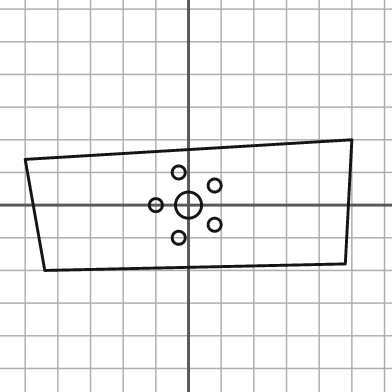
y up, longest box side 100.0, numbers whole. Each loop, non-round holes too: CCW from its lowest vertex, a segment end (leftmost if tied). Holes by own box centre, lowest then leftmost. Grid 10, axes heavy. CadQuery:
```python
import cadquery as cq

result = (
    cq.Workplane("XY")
    .moveTo(-44.0, -20.0)
    .lineTo(48.0, -18.0)
    .lineTo(50.0, 20.0)
    .lineTo(-50.0, 14.0)
    .close()
    .moveTo(-3.0, -10.0)
    .circle(2.0)
    .moveTo(8.0, -6.0)
    .circle(2.0)
    .moveTo(-10.0, 0.0)
    .circle(2.0)
    .moveTo(0.0, 0.0)
    .circle(4.0)
    .moveTo(8.0, 6.0)
    .circle(2.0)
    .moveTo(-3.0, 10.0)
    .circle(2.0)
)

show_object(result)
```